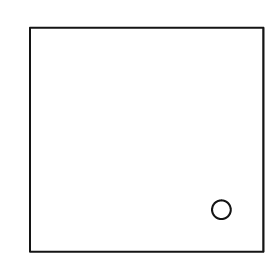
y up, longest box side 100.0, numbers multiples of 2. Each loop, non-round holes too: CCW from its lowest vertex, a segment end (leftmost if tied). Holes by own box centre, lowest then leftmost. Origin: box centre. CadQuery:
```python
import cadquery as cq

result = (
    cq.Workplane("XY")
    .moveTo(-50.0, -48.0)
    .lineTo(50.0, -48.0)
    .lineTo(50.0, 48.0)
    .lineTo(-50.0, 48.0)
    .close()
    .moveTo(32.0, -30.0)
    .circle(4.0)
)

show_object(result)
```